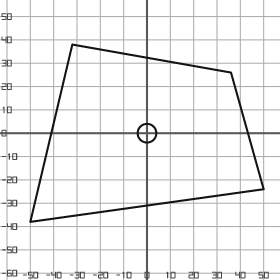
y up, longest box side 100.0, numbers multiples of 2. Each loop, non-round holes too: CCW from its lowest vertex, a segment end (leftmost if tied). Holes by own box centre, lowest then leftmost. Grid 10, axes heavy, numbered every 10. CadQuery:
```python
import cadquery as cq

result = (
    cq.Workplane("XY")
    .moveTo(-50.0, -38.0)
    .lineTo(50.0, -24.0)
    .lineTo(36.0, 26.0)
    .lineTo(-32.0, 38.0)
    .close()
    .moveTo(0.0, 0.0)
    .circle(4.0)
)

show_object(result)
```